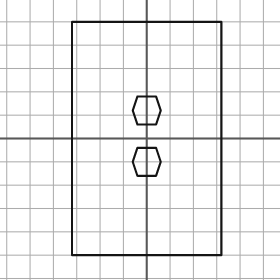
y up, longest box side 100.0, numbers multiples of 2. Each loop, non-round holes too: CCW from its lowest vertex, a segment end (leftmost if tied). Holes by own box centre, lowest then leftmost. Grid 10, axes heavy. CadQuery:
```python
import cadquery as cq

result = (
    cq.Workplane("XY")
    .moveTo(-32.0, -50.0)
    .lineTo(32.0, -50.0)
    .lineTo(32.0, 50.0)
    .lineTo(-32.0, 50.0)
    .close()
    .moveTo(-4.0, -16.0)
    .lineTo(4.0, -16.0)
    .lineTo(6.0, -10.0)
    .lineTo(4.0, -4.0)
    .lineTo(-4.0, -4.0)
    .lineTo(-6.0, -10.0)
    .close()
    .moveTo(-4.0, 6.0)
    .lineTo(4.0, 6.0)
    .lineTo(6.0, 12.0)
    .lineTo(4.0, 18.0)
    .lineTo(-4.0, 18.0)
    .lineTo(-6.0, 12.0)
    .close()
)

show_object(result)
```